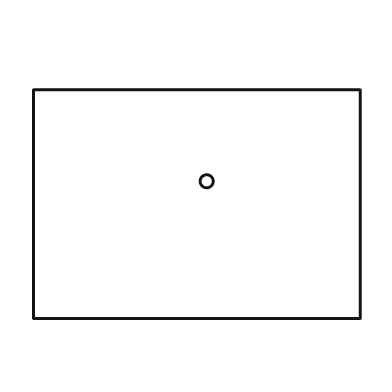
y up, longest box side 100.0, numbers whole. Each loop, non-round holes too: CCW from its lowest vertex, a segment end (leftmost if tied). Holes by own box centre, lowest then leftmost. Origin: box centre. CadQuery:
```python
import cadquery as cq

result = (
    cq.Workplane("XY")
    .moveTo(-50.0, -35.0)
    .lineTo(50.0, -35.0)
    .lineTo(50.0, 35.0)
    .lineTo(-50.0, 35.0)
    .close()
    .moveTo(3.0, 7.0)
    .circle(2.0)
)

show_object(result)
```